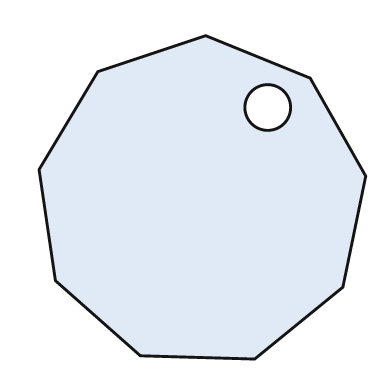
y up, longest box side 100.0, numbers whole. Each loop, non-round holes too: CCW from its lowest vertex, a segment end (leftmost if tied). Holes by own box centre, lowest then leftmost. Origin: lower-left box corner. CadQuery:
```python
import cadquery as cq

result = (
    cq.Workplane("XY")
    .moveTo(66.0, 0.0)
    .lineTo(93.0, 22.0)
    .lineTo(100.0, 56.0)
    .lineTo(83.0, 86.0)
    .lineTo(51.0, 99.0)
    .lineTo(18.0, 88.0)
    .lineTo(0.0, 58.0)
    .lineTo(5.0, 24.0)
    .lineTo(31.0, 1.0)
    .close()
    .moveTo(70.0, 77.0)
    .circle(7.0)
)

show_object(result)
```